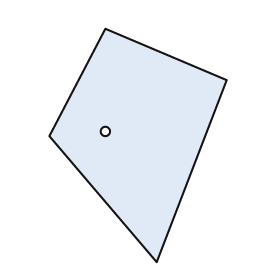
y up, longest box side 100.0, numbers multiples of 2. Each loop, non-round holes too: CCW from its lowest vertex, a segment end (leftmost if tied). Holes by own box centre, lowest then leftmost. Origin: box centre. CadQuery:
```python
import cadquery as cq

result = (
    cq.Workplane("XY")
    .moveTo(8.0, -50.0)
    .lineTo(38.0, 28.0)
    .lineTo(-14.0, 50.0)
    .lineTo(-38.0, 4.0)
    .close()
    .moveTo(-14.0, 6.0)
    .circle(2.0)
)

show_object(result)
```